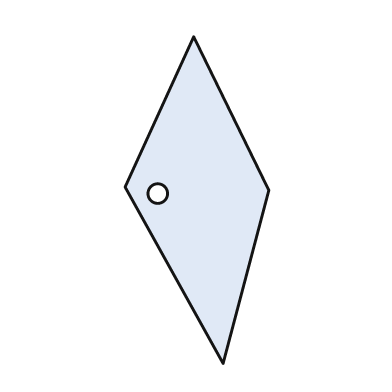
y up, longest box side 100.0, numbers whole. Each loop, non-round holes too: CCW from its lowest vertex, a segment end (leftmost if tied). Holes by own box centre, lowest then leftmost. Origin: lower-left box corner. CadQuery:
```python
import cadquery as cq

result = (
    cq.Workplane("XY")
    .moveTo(30.0, 0.0)
    .lineTo(44.0, 53.0)
    .lineTo(21.0, 100.0)
    .lineTo(0.0, 54.0)
    .close()
    .moveTo(10.0, 52.0)
    .circle(3.0)
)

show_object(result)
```